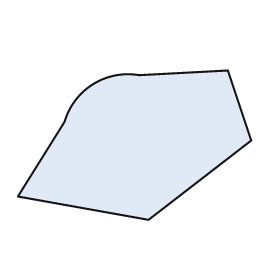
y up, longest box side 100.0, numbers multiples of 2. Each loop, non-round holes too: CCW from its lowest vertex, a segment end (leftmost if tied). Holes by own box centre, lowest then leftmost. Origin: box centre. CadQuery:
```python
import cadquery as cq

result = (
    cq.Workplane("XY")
    .moveTo(6.0, -32.0)
    .lineTo(50.0, 2.0)
    .lineTo(40.0, 32.0)
    .lineTo(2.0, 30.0)
    .threePointArc((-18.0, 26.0), (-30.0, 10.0))
    .lineTo(-50.0, -22.0)
    .close()
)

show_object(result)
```